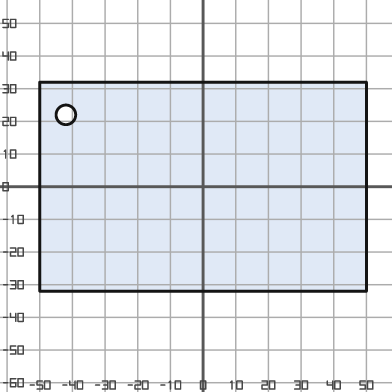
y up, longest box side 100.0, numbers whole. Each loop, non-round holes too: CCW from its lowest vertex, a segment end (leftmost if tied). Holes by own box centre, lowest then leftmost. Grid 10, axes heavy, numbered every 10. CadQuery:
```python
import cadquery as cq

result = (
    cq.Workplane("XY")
    .moveTo(-50.0, -32.0)
    .lineTo(50.0, -32.0)
    .lineTo(50.0, 32.0)
    .lineTo(-50.0, 32.0)
    .close()
    .moveTo(-42.0, 22.0)
    .circle(3.0)
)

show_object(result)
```